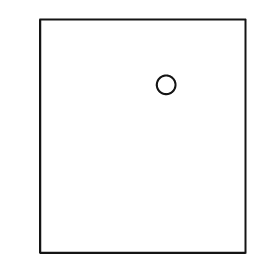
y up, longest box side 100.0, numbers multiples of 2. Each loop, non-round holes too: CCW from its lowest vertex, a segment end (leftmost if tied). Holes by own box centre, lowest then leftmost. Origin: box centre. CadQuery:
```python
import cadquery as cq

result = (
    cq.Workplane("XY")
    .moveTo(-44.0, -50.0)
    .lineTo(44.0, -50.0)
    .lineTo(44.0, 50.0)
    .lineTo(-44.0, 50.0)
    .close()
    .moveTo(10.0, 22.0)
    .circle(4.0)
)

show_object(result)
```